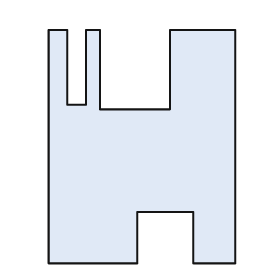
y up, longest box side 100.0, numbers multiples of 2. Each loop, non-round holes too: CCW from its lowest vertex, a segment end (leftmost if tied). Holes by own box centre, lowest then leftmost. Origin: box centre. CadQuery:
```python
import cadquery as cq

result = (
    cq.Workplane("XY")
    .moveTo(-40.0, -50.0)
    .lineTo(-2.0, -50.0)
    .lineTo(-2.0, -28.0)
    .lineTo(22.0, -28.0)
    .lineTo(22.0, -50.0)
    .lineTo(40.0, -50.0)
    .lineTo(40.0, 50.0)
    .lineTo(12.0, 50.0)
    .lineTo(12.0, 16.0)
    .lineTo(-18.0, 16.0)
    .lineTo(-18.0, 50.0)
    .lineTo(-24.0, 50.0)
    .lineTo(-24.0, 18.0)
    .lineTo(-32.0, 18.0)
    .lineTo(-32.0, 50.0)
    .lineTo(-40.0, 50.0)
    .close()
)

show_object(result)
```